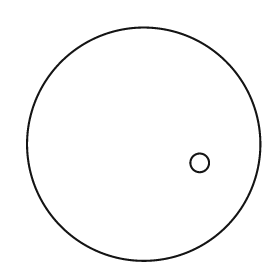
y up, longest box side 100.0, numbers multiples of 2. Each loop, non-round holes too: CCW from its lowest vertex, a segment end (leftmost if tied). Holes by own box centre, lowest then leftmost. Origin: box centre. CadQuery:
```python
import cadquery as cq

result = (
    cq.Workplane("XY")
    .moveTo(0.0, 0.0)
    .circle(50.0)
    .moveTo(24.0, -8.0)
    .circle(4.0)
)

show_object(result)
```